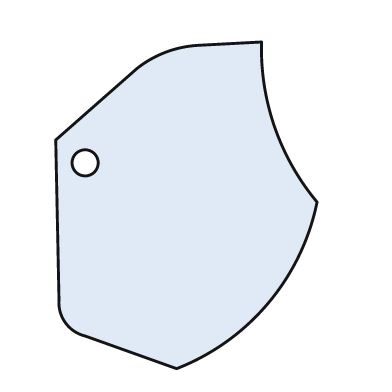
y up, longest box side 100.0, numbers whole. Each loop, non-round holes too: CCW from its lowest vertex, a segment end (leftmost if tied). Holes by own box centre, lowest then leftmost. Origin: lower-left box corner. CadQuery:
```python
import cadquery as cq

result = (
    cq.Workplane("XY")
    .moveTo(37.0, 0.0)
    .threePointArc((65.0, 20.0), (80.0, 51.0))
    .threePointArc((67.0, 74.0), (63.0, 100.0))
    .lineTo(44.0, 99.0)
    .threePointArc((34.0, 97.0), (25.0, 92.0))
    .lineTo(0.0, 70.0)
    .lineTo(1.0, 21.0)
    .threePointArc((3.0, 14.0), (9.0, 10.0))
    .close()
    .moveTo(9.0, 63.0)
    .circle(4.0)
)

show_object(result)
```